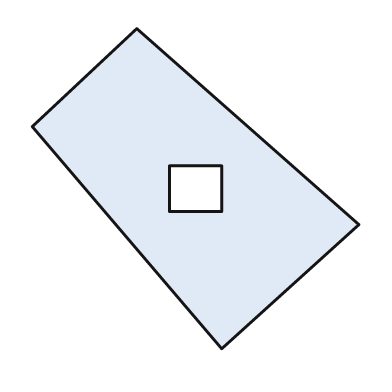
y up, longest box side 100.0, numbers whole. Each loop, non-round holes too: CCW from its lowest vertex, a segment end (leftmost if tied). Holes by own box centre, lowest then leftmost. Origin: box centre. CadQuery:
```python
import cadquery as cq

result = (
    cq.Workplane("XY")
    .moveTo(8.0, -49.0)
    .lineTo(50.0, -11.0)
    .lineTo(-18.0, 49.0)
    .lineTo(-50.0, 19.0)
    .close()
    .moveTo(-8.0, -7.0)
    .lineTo(8.0, -7.0)
    .lineTo(8.0, 7.0)
    .lineTo(-8.0, 7.0)
    .close()
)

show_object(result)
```